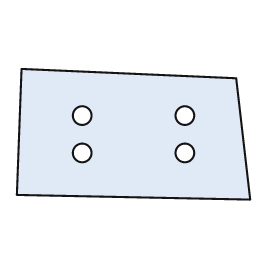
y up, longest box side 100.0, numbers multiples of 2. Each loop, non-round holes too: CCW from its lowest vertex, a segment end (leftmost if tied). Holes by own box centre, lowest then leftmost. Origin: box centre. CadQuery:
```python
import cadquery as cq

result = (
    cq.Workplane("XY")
    .moveTo(50.0, -28.0)
    .lineTo(44.0, 24.0)
    .lineTo(-48.0, 28.0)
    .lineTo(-50.0, -26.0)
    .close()
    .moveTo(-22.0, -8.0)
    .circle(4.0)
    .moveTo(22.0, -8.0)
    .circle(4.0)
    .moveTo(-22.0, 8.0)
    .circle(4.0)
    .moveTo(22.0, 8.0)
    .circle(4.0)
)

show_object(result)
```